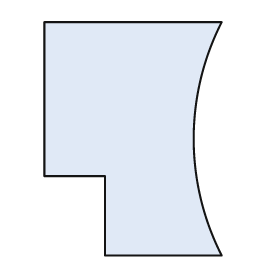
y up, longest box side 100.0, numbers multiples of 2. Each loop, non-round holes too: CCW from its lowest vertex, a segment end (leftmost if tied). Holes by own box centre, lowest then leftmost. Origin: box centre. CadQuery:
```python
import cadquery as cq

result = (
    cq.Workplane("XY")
    .moveTo(-12.0, -50.0)
    .lineTo(38.0, -50.0)
    .threePointArc((26.0, 0.0), (38.0, 50.0))
    .lineTo(-38.0, 50.0)
    .lineTo(-38.0, -16.0)
    .lineTo(-12.0, -16.0)
    .close()
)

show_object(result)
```